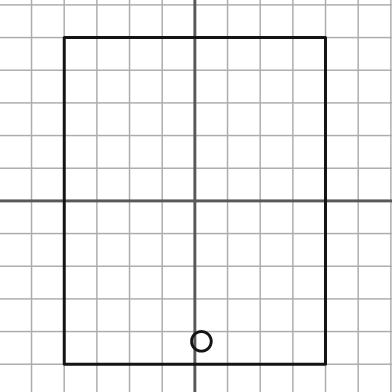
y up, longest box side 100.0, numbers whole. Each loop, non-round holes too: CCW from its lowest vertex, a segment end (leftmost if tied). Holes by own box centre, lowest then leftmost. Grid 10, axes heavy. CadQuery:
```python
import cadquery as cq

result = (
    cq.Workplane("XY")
    .moveTo(-40.0, -50.0)
    .lineTo(40.0, -50.0)
    .lineTo(40.0, 50.0)
    .lineTo(-40.0, 50.0)
    .close()
    .moveTo(2.0, -43.0)
    .circle(3.0)
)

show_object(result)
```